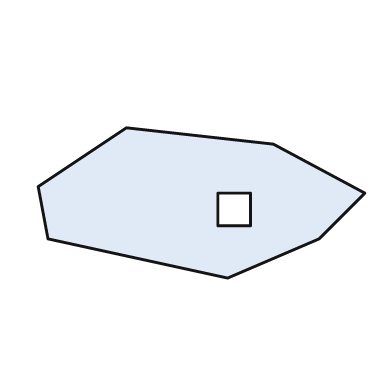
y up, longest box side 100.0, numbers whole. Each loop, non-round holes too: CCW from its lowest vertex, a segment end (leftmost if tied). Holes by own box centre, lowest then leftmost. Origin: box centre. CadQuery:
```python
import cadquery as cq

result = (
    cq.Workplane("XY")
    .moveTo(8.0, -23.0)
    .lineTo(36.0, -11.0)
    .lineTo(50.0, 3.0)
    .lineTo(22.0, 18.0)
    .lineTo(-23.0, 23.0)
    .lineTo(-50.0, 5.0)
    .lineTo(-47.0, -11.0)
    .close()
    .moveTo(5.0, -7.0)
    .lineTo(15.0, -7.0)
    .lineTo(15.0, 3.0)
    .lineTo(5.0, 3.0)
    .close()
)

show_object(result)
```